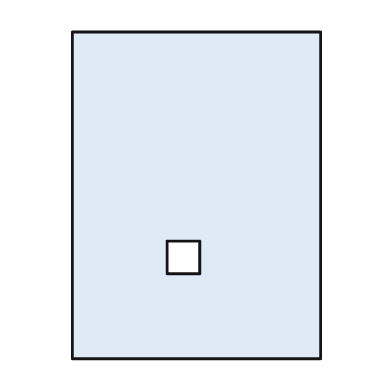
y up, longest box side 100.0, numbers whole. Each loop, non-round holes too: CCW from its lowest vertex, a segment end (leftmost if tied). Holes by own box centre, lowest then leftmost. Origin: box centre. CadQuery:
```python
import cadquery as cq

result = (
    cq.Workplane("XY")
    .moveTo(-38.0, -50.0)
    .lineTo(38.0, -50.0)
    .lineTo(38.0, 50.0)
    .lineTo(-38.0, 50.0)
    .close()
    .moveTo(-9.0, -24.0)
    .lineTo(1.0, -24.0)
    .lineTo(1.0, -14.0)
    .lineTo(-9.0, -14.0)
    .close()
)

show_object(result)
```